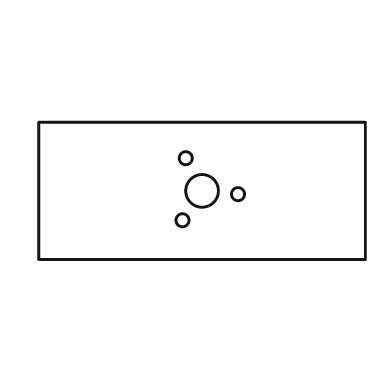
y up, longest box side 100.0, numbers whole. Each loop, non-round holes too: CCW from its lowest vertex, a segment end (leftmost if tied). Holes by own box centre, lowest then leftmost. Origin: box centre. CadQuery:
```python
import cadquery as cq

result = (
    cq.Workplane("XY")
    .moveTo(-50.0, -21.0)
    .lineTo(50.0, -21.0)
    .lineTo(50.0, 21.0)
    .lineTo(-50.0, 21.0)
    .close()
    .moveTo(-6.0, -9.0)
    .circle(2.0)
    .moveTo(11.0, -1.0)
    .circle(2.0)
    .moveTo(0.0, 0.0)
    .circle(5.0)
    .moveTo(-5.0, 10.0)
    .circle(2.0)
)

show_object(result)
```